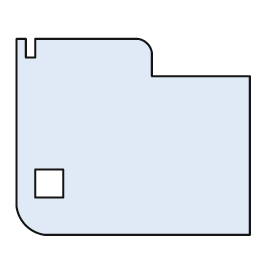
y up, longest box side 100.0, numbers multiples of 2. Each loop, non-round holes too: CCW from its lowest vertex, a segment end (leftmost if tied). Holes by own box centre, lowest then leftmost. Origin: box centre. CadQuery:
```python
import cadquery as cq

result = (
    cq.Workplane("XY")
    .moveTo(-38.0, -42.0)
    .lineTo(50.0, -42.0)
    .lineTo(50.0, 26.0)
    .lineTo(8.0, 26.0)
    .lineTo(8.0, 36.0)
    .threePointArc((6.0, 40.0), (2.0, 42.0))
    .lineTo(-42.0, 42.0)
    .lineTo(-42.0, 34.0)
    .lineTo(-46.0, 34.0)
    .lineTo(-46.0, 42.0)
    .lineTo(-50.0, 42.0)
    .lineTo(-50.0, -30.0)
    .threePointArc((-46.0, -38.0), (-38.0, -42.0))
    .close()
    .moveTo(-42.0, -26.0)
    .lineTo(-30.0, -26.0)
    .lineTo(-30.0, -14.0)
    .lineTo(-42.0, -14.0)
    .close()
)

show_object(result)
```